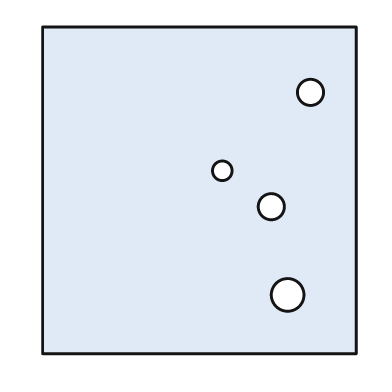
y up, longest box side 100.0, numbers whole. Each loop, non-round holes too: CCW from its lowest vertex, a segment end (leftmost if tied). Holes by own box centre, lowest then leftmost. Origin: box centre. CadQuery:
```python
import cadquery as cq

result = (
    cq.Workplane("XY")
    .moveTo(-48.0, -50.0)
    .lineTo(48.0, -50.0)
    .lineTo(48.0, 50.0)
    .lineTo(-48.0, 50.0)
    .close()
    .moveTo(27.0, -32.0)
    .circle(5.0)
    .moveTo(22.0, -5.0)
    .circle(4.0)
    .moveTo(7.0, 6.0)
    .circle(3.0)
    .moveTo(34.0, 30.0)
    .circle(4.0)
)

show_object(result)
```